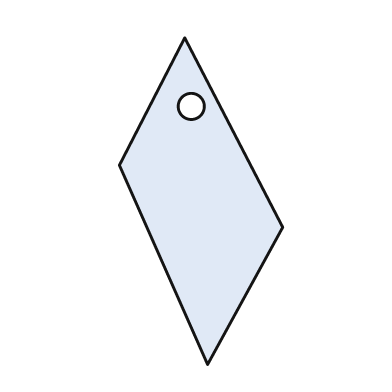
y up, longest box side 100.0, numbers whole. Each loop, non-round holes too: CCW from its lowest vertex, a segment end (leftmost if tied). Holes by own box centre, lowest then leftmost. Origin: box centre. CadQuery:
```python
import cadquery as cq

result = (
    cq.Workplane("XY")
    .moveTo(2.0, -50.0)
    .lineTo(25.0, -8.0)
    .lineTo(-5.0, 50.0)
    .lineTo(-25.0, 11.0)
    .close()
    .moveTo(-3.0, 29.0)
    .circle(4.0)
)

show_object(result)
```